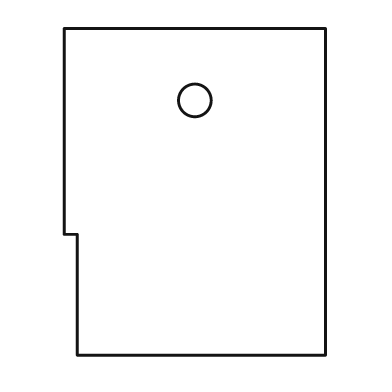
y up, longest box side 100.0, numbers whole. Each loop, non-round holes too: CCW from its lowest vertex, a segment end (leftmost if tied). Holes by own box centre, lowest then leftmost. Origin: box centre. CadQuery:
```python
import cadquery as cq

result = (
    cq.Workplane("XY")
    .moveTo(-36.0, -50.0)
    .lineTo(40.0, -50.0)
    .lineTo(40.0, 50.0)
    .lineTo(-40.0, 50.0)
    .lineTo(-40.0, -13.0)
    .lineTo(-36.0, -13.0)
    .close()
    .moveTo(0.0, 28.0)
    .circle(5.0)
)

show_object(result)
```